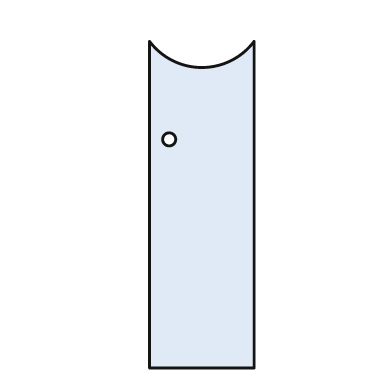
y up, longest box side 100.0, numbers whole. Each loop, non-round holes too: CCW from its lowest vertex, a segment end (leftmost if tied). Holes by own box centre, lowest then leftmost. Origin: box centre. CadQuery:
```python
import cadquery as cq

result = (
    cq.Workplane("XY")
    .moveTo(-16.0, -50.0)
    .lineTo(16.0, -50.0)
    .lineTo(16.0, 50.0)
    .threePointArc((0.0, 42.0), (-16.0, 50.0))
    .close()
    .moveTo(-10.0, 20.0)
    .circle(2.0)
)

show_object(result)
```